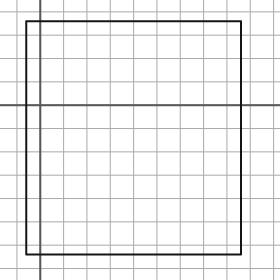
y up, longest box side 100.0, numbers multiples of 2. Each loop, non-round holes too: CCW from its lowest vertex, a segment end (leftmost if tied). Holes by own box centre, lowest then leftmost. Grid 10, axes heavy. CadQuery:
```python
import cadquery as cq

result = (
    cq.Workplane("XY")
    .moveTo(-6.0, -64.0)
    .lineTo(86.0, -64.0)
    .lineTo(86.0, 36.0)
    .lineTo(-6.0, 36.0)
    .close()
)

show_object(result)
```